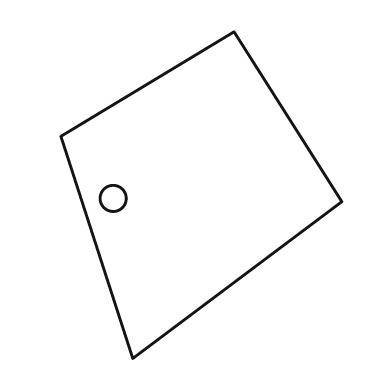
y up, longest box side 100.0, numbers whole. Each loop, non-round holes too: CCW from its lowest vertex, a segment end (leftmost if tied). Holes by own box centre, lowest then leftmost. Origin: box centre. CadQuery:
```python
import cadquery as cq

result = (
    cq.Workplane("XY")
    .moveTo(-21.0, -50.0)
    .lineTo(43.0, -2.0)
    .lineTo(10.0, 50.0)
    .lineTo(-43.0, 18.0)
    .close()
    .moveTo(-27.0, -1.0)
    .circle(4.0)
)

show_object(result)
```